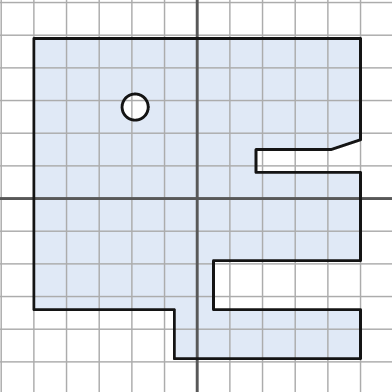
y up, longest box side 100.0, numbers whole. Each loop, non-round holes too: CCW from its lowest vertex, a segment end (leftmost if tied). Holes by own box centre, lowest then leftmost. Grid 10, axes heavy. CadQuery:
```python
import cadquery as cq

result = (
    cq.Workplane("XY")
    .moveTo(-7.0, -49.0)
    .lineTo(50.0, -49.0)
    .lineTo(50.0, -34.0)
    .lineTo(5.0, -34.0)
    .lineTo(5.0, -19.0)
    .lineTo(50.0, -19.0)
    .lineTo(50.0, 8.0)
    .lineTo(18.0, 8.0)
    .lineTo(18.0, 15.0)
    .lineTo(41.0, 15.0)
    .lineTo(50.0, 18.0)
    .lineTo(50.0, 49.0)
    .lineTo(-50.0, 49.0)
    .lineTo(-50.0, -34.0)
    .lineTo(-7.0, -34.0)
    .close()
    .moveTo(-19.0, 28.0)
    .circle(4.0)
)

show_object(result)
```